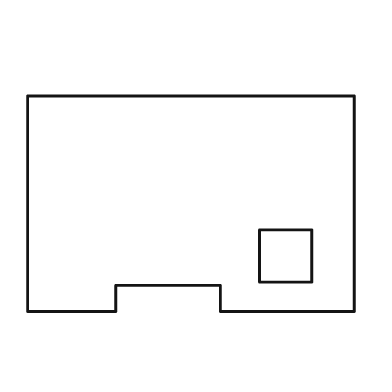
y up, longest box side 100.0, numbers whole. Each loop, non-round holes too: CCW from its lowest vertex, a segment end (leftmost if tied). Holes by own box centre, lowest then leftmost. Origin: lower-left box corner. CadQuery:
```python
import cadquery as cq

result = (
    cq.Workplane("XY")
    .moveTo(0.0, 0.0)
    .lineTo(27.0, 0.0)
    .lineTo(27.0, 8.0)
    .lineTo(59.0, 8.0)
    .lineTo(59.0, 0.0)
    .lineTo(100.0, 0.0)
    .lineTo(100.0, 66.0)
    .lineTo(0.0, 66.0)
    .close()
    .moveTo(71.0, 9.0)
    .lineTo(87.0, 9.0)
    .lineTo(87.0, 25.0)
    .lineTo(71.0, 25.0)
    .close()
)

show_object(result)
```